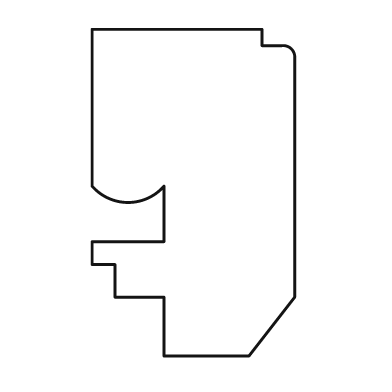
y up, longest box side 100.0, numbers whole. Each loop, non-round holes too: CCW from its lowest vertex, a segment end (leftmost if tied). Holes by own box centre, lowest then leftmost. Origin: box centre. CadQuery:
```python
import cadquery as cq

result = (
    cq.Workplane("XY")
    .moveTo(-9.0, -50.0)
    .lineTo(17.0, -50.0)
    .lineTo(31.0, -32.0)
    .lineTo(31.0, 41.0)
    .threePointArc((30.0, 44.0), (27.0, 45.0))
    .lineTo(21.0, 45.0)
    .lineTo(21.0, 50.0)
    .lineTo(-31.0, 50.0)
    .lineTo(-31.0, 2.0)
    .threePointArc((-20.0, -3.0), (-9.0, 2.0))
    .lineTo(-9.0, -15.0)
    .lineTo(-31.0, -15.0)
    .lineTo(-31.0, -22.0)
    .lineTo(-24.0, -22.0)
    .lineTo(-24.0, -32.0)
    .lineTo(-9.0, -32.0)
    .close()
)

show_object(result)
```